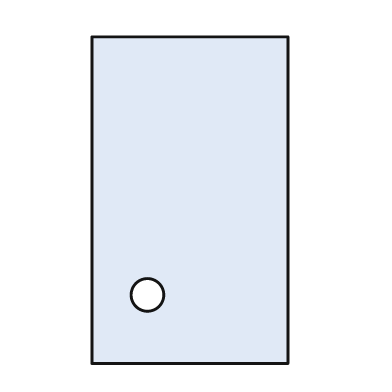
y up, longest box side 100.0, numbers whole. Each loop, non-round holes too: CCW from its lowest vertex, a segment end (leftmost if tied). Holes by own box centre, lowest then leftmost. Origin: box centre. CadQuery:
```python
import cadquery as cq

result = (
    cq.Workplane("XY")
    .moveTo(-30.0, -50.0)
    .lineTo(30.0, -50.0)
    .lineTo(30.0, 50.0)
    .lineTo(-30.0, 50.0)
    .close()
    .moveTo(-13.0, -29.0)
    .circle(5.0)
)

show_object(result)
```